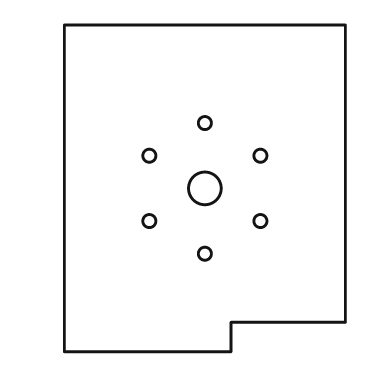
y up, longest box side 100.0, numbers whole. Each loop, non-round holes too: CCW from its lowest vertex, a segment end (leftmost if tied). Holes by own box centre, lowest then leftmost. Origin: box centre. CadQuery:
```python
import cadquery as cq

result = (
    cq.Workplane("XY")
    .moveTo(-43.0, -50.0)
    .lineTo(8.0, -50.0)
    .lineTo(8.0, -41.0)
    .lineTo(43.0, -41.0)
    .lineTo(43.0, 50.0)
    .lineTo(-43.0, 50.0)
    .close()
    .moveTo(0.0, -20.0)
    .circle(2.0)
    .moveTo(-17.0, -10.0)
    .circle(2.0)
    .moveTo(17.0, -10.0)
    .circle(2.0)
    .moveTo(0.0, 0.0)
    .circle(5.0)
    .moveTo(-17.0, 10.0)
    .circle(2.0)
    .moveTo(17.0, 10.0)
    .circle(2.0)
    .moveTo(0.0, 20.0)
    .circle(2.0)
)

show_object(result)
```